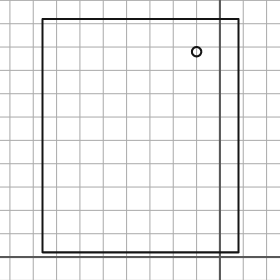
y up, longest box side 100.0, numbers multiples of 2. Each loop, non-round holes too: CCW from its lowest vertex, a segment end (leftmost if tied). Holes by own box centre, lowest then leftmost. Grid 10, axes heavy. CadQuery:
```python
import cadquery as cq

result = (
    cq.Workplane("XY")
    .moveTo(-76.0, 2.0)
    .lineTo(8.0, 2.0)
    .lineTo(8.0, 102.0)
    .lineTo(-76.0, 102.0)
    .close()
    .moveTo(-10.0, 88.0)
    .circle(2.0)
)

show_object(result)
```